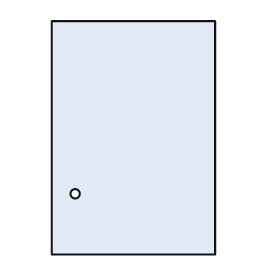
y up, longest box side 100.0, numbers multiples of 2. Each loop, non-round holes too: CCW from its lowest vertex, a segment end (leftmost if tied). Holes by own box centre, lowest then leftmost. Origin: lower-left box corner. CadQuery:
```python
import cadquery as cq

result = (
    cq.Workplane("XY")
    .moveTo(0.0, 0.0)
    .lineTo(70.0, 0.0)
    .lineTo(70.0, 100.0)
    .lineTo(0.0, 100.0)
    .close()
    .moveTo(10.0, 26.0)
    .circle(2.0)
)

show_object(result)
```